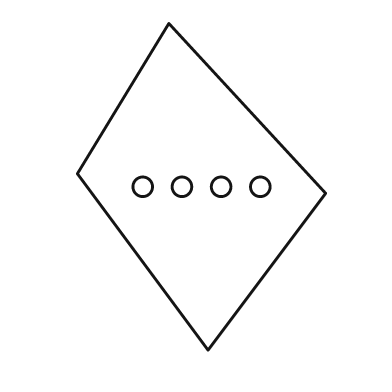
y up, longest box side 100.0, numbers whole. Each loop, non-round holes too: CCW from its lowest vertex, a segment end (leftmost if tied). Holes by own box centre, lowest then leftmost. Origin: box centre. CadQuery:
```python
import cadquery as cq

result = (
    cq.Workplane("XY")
    .moveTo(2.0, -50.0)
    .lineTo(38.0, -2.0)
    .lineTo(-10.0, 50.0)
    .lineTo(-38.0, 4.0)
    .close()
    .moveTo(-18.0, 0.0)
    .circle(3.0)
    .moveTo(-6.0, 0.0)
    .circle(3.0)
    .moveTo(6.0, 0.0)
    .circle(3.0)
    .moveTo(18.0, 0.0)
    .circle(3.0)
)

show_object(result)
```